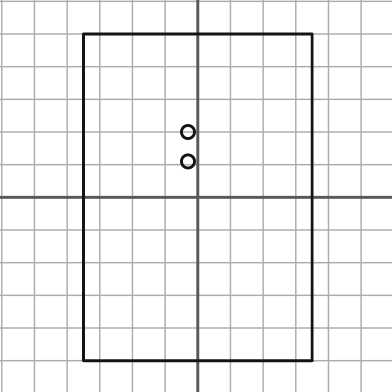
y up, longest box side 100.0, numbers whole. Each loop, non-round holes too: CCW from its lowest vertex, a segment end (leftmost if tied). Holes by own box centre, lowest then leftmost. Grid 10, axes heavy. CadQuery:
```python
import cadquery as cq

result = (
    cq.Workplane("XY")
    .moveTo(-35.0, -50.0)
    .lineTo(35.0, -50.0)
    .lineTo(35.0, 50.0)
    .lineTo(-35.0, 50.0)
    .close()
    .moveTo(-3.0, 11.0)
    .circle(2.0)
    .moveTo(-3.0, 20.0)
    .circle(2.0)
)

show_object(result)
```